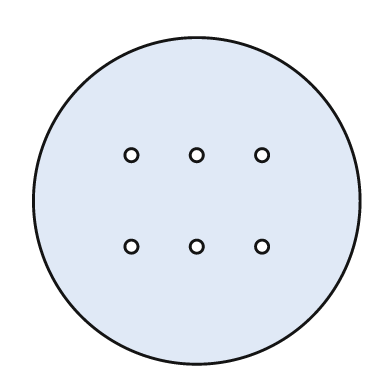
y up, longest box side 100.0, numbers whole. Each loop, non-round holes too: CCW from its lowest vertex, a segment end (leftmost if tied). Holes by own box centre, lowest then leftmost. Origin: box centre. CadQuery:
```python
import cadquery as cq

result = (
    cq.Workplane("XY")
    .moveTo(0.0, 0.0)
    .circle(50.0)
    .moveTo(-20.0, -14.0)
    .circle(2.0)
    .moveTo(0.0, -14.0)
    .circle(2.0)
    .moveTo(20.0, -14.0)
    .circle(2.0)
    .moveTo(-20.0, 14.0)
    .circle(2.0)
    .moveTo(0.0, 14.0)
    .circle(2.0)
    .moveTo(20.0, 14.0)
    .circle(2.0)
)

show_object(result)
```